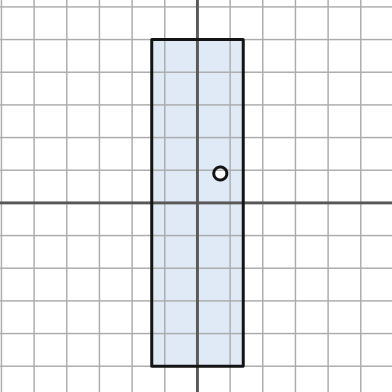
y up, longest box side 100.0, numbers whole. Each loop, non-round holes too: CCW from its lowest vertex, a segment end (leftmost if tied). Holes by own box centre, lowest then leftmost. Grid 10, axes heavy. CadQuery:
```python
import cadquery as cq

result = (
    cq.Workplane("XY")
    .moveTo(-14.0, -50.0)
    .lineTo(14.0, -50.0)
    .lineTo(14.0, 50.0)
    .lineTo(-14.0, 50.0)
    .close()
    .moveTo(7.0, 9.0)
    .circle(2.0)
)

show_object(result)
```